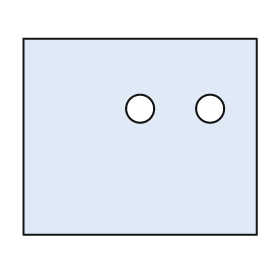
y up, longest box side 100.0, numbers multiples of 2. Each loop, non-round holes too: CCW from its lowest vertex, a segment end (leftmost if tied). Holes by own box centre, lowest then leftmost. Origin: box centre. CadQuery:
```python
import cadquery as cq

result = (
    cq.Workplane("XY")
    .moveTo(-50.0, -42.0)
    .lineTo(50.0, -42.0)
    .lineTo(50.0, 42.0)
    .lineTo(-50.0, 42.0)
    .close()
    .moveTo(0.0, 12.0)
    .circle(6.0)
    .moveTo(30.0, 12.0)
    .circle(6.0)
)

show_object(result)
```